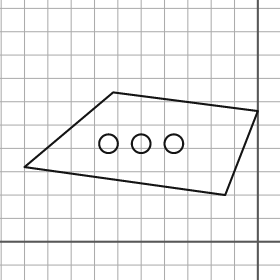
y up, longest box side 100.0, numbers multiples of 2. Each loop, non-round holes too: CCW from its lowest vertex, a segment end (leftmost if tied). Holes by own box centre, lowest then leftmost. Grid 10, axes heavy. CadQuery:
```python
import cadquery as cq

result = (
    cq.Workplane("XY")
    .moveTo(-14.0, 20.0)
    .lineTo(0.0, 56.0)
    .lineTo(-62.0, 64.0)
    .lineTo(-100.0, 32.0)
    .close()
    .moveTo(-64.0, 42.0)
    .circle(4.0)
    .moveTo(-50.0, 42.0)
    .circle(4.0)
    .moveTo(-36.0, 42.0)
    .circle(4.0)
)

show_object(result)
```